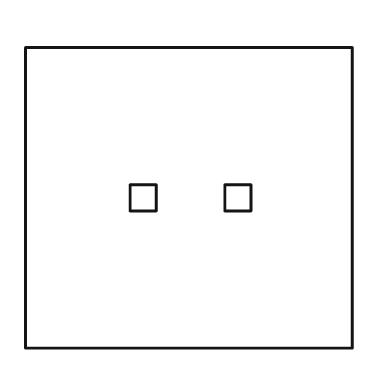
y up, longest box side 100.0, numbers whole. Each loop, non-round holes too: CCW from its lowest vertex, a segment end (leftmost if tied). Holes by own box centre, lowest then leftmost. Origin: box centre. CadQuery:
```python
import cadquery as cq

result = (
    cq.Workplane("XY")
    .moveTo(-50.0, -46.0)
    .lineTo(50.0, -46.0)
    .lineTo(50.0, 46.0)
    .lineTo(-50.0, 46.0)
    .close()
    .moveTo(-18.0, -4.0)
    .lineTo(-10.0, -4.0)
    .lineTo(-10.0, 4.0)
    .lineTo(-18.0, 4.0)
    .close()
    .moveTo(11.0, -4.0)
    .lineTo(19.0, -4.0)
    .lineTo(19.0, 4.0)
    .lineTo(11.0, 4.0)
    .close()
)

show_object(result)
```